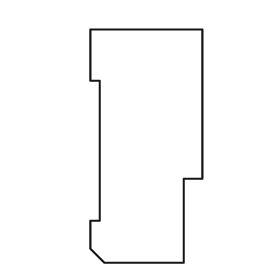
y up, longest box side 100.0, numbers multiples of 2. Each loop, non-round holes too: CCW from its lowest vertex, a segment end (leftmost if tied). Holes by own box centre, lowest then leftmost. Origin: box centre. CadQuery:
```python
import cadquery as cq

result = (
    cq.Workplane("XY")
    .moveTo(-18.0, -50.0)
    .lineTo(16.0, -50.0)
    .lineTo(16.0, -14.0)
    .lineTo(24.0, -14.0)
    .lineTo(24.0, 50.0)
    .lineTo(-24.0, 50.0)
    .lineTo(-24.0, 28.0)
    .lineTo(-20.0, 28.0)
    .lineTo(-20.0, -32.0)
    .lineTo(-24.0, -32.0)
    .lineTo(-24.0, -44.0)
    .close()
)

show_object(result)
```